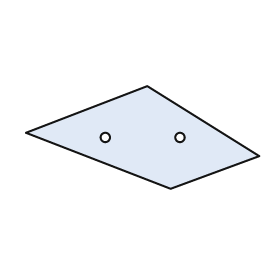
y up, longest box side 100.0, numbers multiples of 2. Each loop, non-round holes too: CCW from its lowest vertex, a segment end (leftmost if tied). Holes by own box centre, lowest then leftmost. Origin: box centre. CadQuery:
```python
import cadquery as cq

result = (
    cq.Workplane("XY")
    .moveTo(12.0, -22.0)
    .lineTo(50.0, -8.0)
    .lineTo(2.0, 22.0)
    .lineTo(-50.0, 2.0)
    .close()
    .moveTo(-16.0, 0.0)
    .circle(2.0)
    .moveTo(16.0, 0.0)
    .circle(2.0)
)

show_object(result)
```